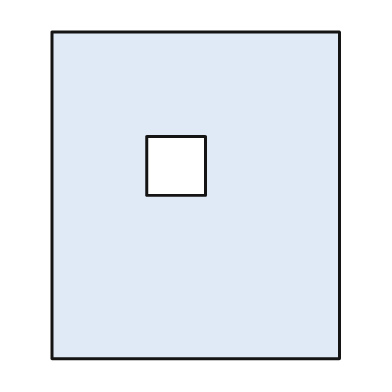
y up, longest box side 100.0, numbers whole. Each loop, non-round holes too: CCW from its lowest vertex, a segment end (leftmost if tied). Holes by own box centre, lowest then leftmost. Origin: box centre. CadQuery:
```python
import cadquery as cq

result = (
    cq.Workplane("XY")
    .moveTo(-44.0, -50.0)
    .lineTo(44.0, -50.0)
    .lineTo(44.0, 50.0)
    .lineTo(-44.0, 50.0)
    .close()
    .moveTo(-15.0, 0.0)
    .lineTo(3.0, 0.0)
    .lineTo(3.0, 18.0)
    .lineTo(-15.0, 18.0)
    .close()
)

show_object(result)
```